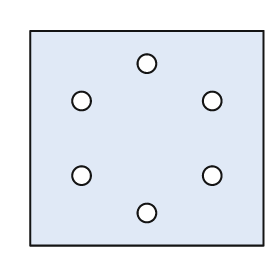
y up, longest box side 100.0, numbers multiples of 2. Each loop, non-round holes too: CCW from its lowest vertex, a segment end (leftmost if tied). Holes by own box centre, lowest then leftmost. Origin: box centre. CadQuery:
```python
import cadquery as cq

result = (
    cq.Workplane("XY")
    .moveTo(-50.0, -46.0)
    .lineTo(50.0, -46.0)
    .lineTo(50.0, 46.0)
    .lineTo(-50.0, 46.0)
    .close()
    .moveTo(0.0, -32.0)
    .circle(4.0)
    .moveTo(-28.0, -16.0)
    .circle(4.0)
    .moveTo(28.0, -16.0)
    .circle(4.0)
    .moveTo(-28.0, 16.0)
    .circle(4.0)
    .moveTo(28.0, 16.0)
    .circle(4.0)
    .moveTo(0.0, 32.0)
    .circle(4.0)
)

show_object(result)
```